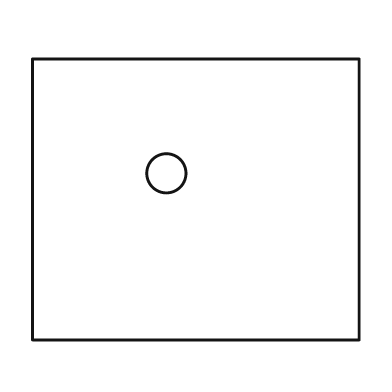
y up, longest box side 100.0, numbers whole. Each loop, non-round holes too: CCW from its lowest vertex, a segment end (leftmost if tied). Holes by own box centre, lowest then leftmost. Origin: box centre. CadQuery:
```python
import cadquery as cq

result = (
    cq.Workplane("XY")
    .moveTo(-50.0, -43.0)
    .lineTo(50.0, -43.0)
    .lineTo(50.0, 43.0)
    .lineTo(-50.0, 43.0)
    .close()
    .moveTo(-9.0, 8.0)
    .circle(6.0)
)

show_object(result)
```